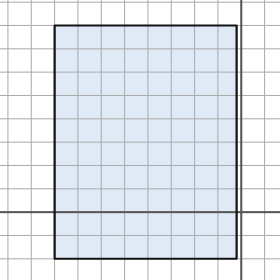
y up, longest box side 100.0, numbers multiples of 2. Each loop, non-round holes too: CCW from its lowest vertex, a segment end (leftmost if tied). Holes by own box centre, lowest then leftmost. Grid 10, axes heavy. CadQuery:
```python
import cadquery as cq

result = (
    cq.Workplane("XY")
    .moveTo(-80.0, -20.0)
    .lineTo(-2.0, -20.0)
    .lineTo(-2.0, 80.0)
    .lineTo(-80.0, 80.0)
    .close()
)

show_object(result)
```